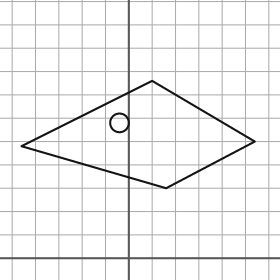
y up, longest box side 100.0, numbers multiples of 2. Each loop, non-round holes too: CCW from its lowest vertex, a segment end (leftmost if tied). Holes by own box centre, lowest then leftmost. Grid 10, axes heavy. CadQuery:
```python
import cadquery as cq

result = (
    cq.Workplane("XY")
    .moveTo(16.0, 30.0)
    .lineTo(54.0, 50.0)
    .lineTo(10.0, 76.0)
    .lineTo(-46.0, 48.0)
    .close()
    .moveTo(-4.0, 58.0)
    .circle(4.0)
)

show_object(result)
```